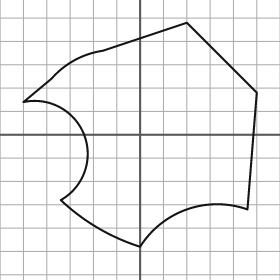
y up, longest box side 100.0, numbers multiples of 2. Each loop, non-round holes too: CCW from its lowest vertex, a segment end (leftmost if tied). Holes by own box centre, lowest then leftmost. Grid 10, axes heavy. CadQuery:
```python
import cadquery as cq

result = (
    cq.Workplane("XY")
    .moveTo(0.0, -48.0)
    .threePointArc((20.0, -32.0), (46.0, -32.0))
    .lineTo(50.0, 18.0)
    .lineTo(20.0, 48.0)
    .lineTo(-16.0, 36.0)
    .threePointArc((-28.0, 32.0), (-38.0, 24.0))
    .lineTo(-50.0, 14.0)
    .threePointArc((-24.0, 0.0), (-34.0, -28.0))
    .threePointArc((-18.0, -40.0), (0.0, -48.0))
    .close()
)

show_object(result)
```